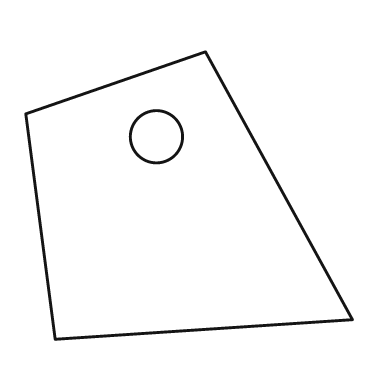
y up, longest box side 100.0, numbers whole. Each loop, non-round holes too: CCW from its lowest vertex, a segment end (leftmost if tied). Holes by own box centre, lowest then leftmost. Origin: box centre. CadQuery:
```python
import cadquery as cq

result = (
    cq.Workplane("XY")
    .moveTo(-41.0, -44.0)
    .lineTo(50.0, -38.0)
    .lineTo(5.0, 44.0)
    .lineTo(-50.0, 25.0)
    .close()
    .moveTo(-10.0, 18.0)
    .circle(8.0)
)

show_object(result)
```